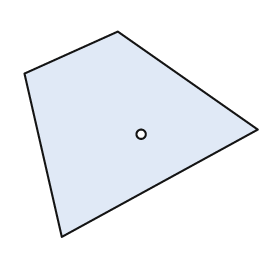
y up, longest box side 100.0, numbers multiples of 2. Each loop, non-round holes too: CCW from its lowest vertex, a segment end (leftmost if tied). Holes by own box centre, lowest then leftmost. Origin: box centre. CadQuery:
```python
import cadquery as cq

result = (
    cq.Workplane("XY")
    .moveTo(-34.0, -44.0)
    .lineTo(50.0, 2.0)
    .lineTo(-10.0, 44.0)
    .lineTo(-50.0, 26.0)
    .close()
    .moveTo(0.0, 0.0)
    .circle(2.0)
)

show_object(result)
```